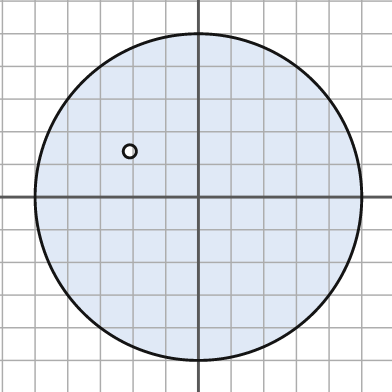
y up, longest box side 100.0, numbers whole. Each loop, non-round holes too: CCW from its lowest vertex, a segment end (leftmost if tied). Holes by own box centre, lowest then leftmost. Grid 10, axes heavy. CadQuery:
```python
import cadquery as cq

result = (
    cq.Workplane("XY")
    .moveTo(0.0, 0.0)
    .circle(50.0)
    .moveTo(-21.0, 14.0)
    .circle(2.0)
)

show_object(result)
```